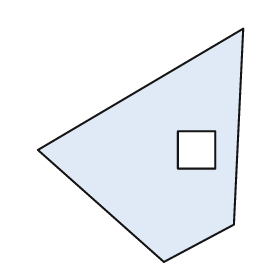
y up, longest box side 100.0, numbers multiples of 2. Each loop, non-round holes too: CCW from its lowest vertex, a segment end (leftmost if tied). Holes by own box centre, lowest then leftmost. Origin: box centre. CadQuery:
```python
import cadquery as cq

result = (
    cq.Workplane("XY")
    .moveTo(10.0, -50.0)
    .lineTo(40.0, -34.0)
    .lineTo(44.0, 50.0)
    .lineTo(-44.0, -2.0)
    .close()
    .moveTo(16.0, -10.0)
    .lineTo(32.0, -10.0)
    .lineTo(32.0, 6.0)
    .lineTo(16.0, 6.0)
    .close()
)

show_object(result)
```